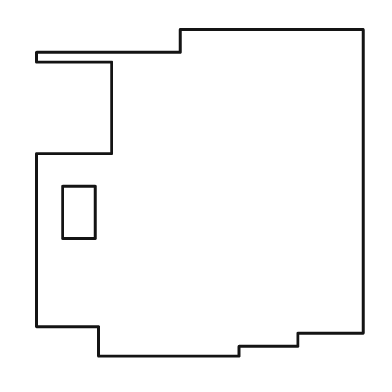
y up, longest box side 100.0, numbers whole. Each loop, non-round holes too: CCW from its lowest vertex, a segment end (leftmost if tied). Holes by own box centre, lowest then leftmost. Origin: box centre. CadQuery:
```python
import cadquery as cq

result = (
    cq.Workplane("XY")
    .moveTo(-31.0, -50.0)
    .lineTo(12.0, -50.0)
    .lineTo(12.0, -47.0)
    .lineTo(30.0, -47.0)
    .lineTo(30.0, -43.0)
    .lineTo(50.0, -43.0)
    .lineTo(50.0, 50.0)
    .lineTo(-6.0, 50.0)
    .lineTo(-6.0, 43.0)
    .lineTo(-50.0, 43.0)
    .lineTo(-50.0, 40.0)
    .lineTo(-27.0, 40.0)
    .lineTo(-27.0, 12.0)
    .lineTo(-50.0, 12.0)
    .lineTo(-50.0, -41.0)
    .lineTo(-31.0, -41.0)
    .close()
    .moveTo(-42.0, -14.0)
    .lineTo(-32.0, -14.0)
    .lineTo(-32.0, 2.0)
    .lineTo(-42.0, 2.0)
    .close()
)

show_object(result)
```